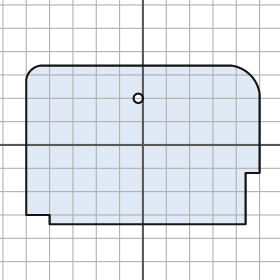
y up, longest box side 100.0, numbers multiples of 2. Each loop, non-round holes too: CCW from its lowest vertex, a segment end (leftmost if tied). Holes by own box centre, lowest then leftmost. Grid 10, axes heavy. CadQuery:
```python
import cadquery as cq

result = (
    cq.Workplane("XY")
    .moveTo(-40.0, -34.0)
    .lineTo(44.0, -34.0)
    .lineTo(44.0, -12.0)
    .lineTo(50.0, -12.0)
    .lineTo(50.0, 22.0)
    .threePointArc((46.0, 30.0), (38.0, 34.0))
    .lineTo(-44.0, 34.0)
    .threePointArc((-48.0, 32.0), (-50.0, 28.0))
    .lineTo(-50.0, -30.0)
    .lineTo(-40.0, -30.0)
    .close()
    .moveTo(-2.0, 20.0)
    .circle(2.0)
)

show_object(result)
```